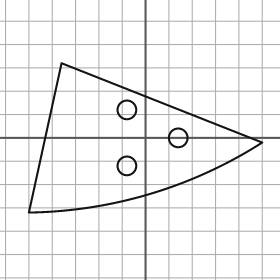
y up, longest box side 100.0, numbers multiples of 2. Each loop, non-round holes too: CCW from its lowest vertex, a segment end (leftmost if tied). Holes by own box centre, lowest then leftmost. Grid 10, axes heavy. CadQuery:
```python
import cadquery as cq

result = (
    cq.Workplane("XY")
    .moveTo(-50.0, -32.0)
    .threePointArc((2.0, -24.0), (50.0, -2.0))
    .lineTo(-36.0, 32.0)
    .close()
    .moveTo(-8.0, -12.0)
    .circle(4.0)
    .moveTo(14.0, 0.0)
    .circle(4.0)
    .moveTo(-8.0, 12.0)
    .circle(4.0)
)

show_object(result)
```